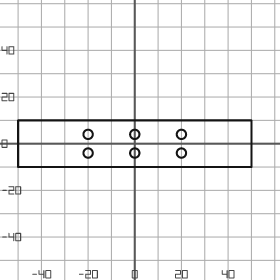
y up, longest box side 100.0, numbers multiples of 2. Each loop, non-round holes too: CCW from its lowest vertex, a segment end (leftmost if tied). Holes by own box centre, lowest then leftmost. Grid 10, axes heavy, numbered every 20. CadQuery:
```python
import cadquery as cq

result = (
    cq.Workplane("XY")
    .moveTo(-50.0, -10.0)
    .lineTo(50.0, -10.0)
    .lineTo(50.0, 10.0)
    .lineTo(-50.0, 10.0)
    .close()
    .moveTo(-20.0, -4.0)
    .circle(2.0)
    .moveTo(0.0, -4.0)
    .circle(2.0)
    .moveTo(20.0, -4.0)
    .circle(2.0)
    .moveTo(-20.0, 4.0)
    .circle(2.0)
    .moveTo(0.0, 4.0)
    .circle(2.0)
    .moveTo(20.0, 4.0)
    .circle(2.0)
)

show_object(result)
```